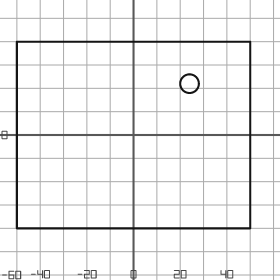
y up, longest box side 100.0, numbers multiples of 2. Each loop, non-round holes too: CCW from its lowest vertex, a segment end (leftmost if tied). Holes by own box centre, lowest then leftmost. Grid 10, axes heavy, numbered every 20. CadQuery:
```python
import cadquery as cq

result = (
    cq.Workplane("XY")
    .moveTo(-50.0, -40.0)
    .lineTo(50.0, -40.0)
    .lineTo(50.0, 40.0)
    .lineTo(-50.0, 40.0)
    .close()
    .moveTo(24.0, 22.0)
    .circle(4.0)
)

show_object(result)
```